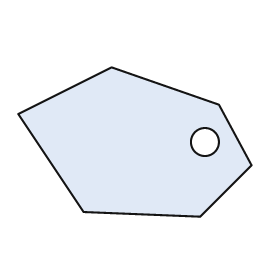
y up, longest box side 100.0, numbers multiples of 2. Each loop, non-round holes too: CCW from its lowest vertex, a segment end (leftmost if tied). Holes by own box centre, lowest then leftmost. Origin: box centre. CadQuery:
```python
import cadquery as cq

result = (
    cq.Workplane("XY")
    .moveTo(28.0, -32.0)
    .lineTo(50.0, -10.0)
    .lineTo(36.0, 16.0)
    .lineTo(-10.0, 32.0)
    .lineTo(-50.0, 12.0)
    .lineTo(-22.0, -30.0)
    .close()
    .moveTo(30.0, 0.0)
    .circle(6.0)
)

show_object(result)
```